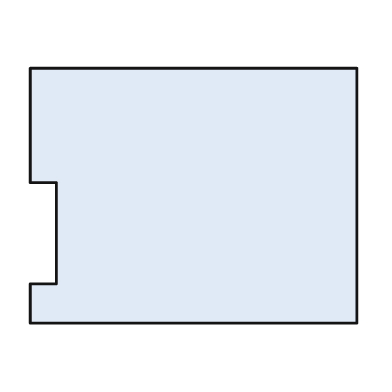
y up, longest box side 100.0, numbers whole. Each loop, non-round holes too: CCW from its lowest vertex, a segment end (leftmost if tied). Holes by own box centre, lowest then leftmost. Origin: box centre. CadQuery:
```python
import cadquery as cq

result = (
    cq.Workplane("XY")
    .moveTo(-50.0, -39.0)
    .lineTo(50.0, -39.0)
    .lineTo(50.0, 39.0)
    .lineTo(-50.0, 39.0)
    .lineTo(-50.0, 4.0)
    .lineTo(-42.0, 4.0)
    .lineTo(-42.0, -27.0)
    .lineTo(-50.0, -27.0)
    .close()
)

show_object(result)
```